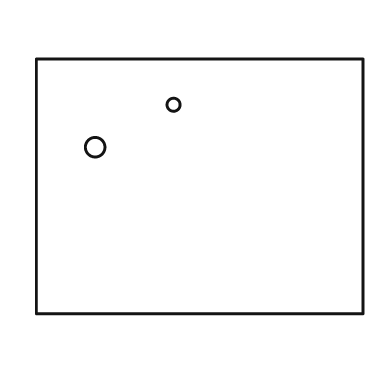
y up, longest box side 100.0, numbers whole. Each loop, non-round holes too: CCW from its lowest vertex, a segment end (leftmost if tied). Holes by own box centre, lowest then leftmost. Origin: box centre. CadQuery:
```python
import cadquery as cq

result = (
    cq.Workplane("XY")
    .moveTo(-50.0, -39.0)
    .lineTo(50.0, -39.0)
    .lineTo(50.0, 39.0)
    .lineTo(-50.0, 39.0)
    .close()
    .moveTo(-32.0, 12.0)
    .circle(3.0)
    .moveTo(-8.0, 25.0)
    .circle(2.0)
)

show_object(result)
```